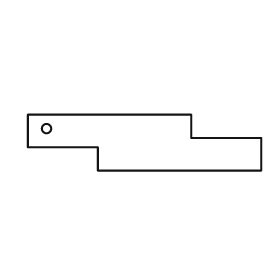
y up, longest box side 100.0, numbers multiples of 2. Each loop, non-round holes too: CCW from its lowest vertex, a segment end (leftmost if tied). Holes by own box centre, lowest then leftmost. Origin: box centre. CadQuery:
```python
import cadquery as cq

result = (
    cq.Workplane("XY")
    .moveTo(-20.0, -12.0)
    .lineTo(50.0, -12.0)
    .lineTo(50.0, 2.0)
    .lineTo(20.0, 2.0)
    .lineTo(20.0, 12.0)
    .lineTo(-50.0, 12.0)
    .lineTo(-50.0, -2.0)
    .lineTo(-20.0, -2.0)
    .close()
    .moveTo(-42.0, 6.0)
    .circle(2.0)
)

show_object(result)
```